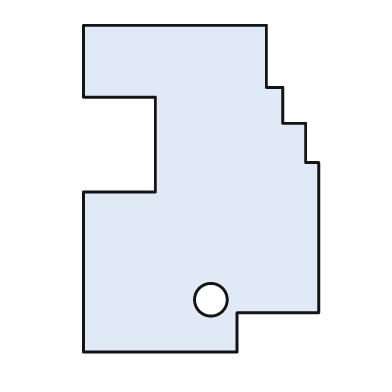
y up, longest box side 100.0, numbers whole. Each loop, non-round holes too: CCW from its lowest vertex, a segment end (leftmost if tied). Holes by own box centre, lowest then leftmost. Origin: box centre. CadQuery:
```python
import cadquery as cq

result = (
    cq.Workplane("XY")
    .moveTo(-36.0, -50.0)
    .lineTo(11.0, -50.0)
    .lineTo(11.0, -38.0)
    .lineTo(36.0, -38.0)
    .lineTo(36.0, 8.0)
    .lineTo(32.0, 8.0)
    .lineTo(32.0, 20.0)
    .lineTo(25.0, 20.0)
    .lineTo(25.0, 31.0)
    .lineTo(20.0, 31.0)
    .lineTo(20.0, 50.0)
    .lineTo(-36.0, 50.0)
    .lineTo(-36.0, 28.0)
    .lineTo(-14.0, 28.0)
    .lineTo(-14.0, -1.0)
    .lineTo(-36.0, -1.0)
    .close()
    .moveTo(3.0, -34.0)
    .circle(5.0)
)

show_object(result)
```